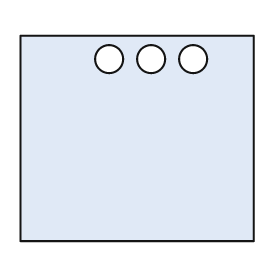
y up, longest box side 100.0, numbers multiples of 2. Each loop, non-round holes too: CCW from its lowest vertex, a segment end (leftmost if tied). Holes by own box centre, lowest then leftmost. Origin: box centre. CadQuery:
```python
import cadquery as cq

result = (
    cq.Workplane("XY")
    .moveTo(-50.0, -44.0)
    .lineTo(50.0, -44.0)
    .lineTo(50.0, 44.0)
    .lineTo(-50.0, 44.0)
    .close()
    .moveTo(-12.0, 34.0)
    .circle(6.0)
    .moveTo(6.0, 34.0)
    .circle(6.0)
    .moveTo(24.0, 34.0)
    .circle(6.0)
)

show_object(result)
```